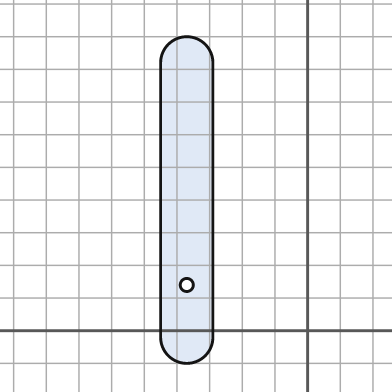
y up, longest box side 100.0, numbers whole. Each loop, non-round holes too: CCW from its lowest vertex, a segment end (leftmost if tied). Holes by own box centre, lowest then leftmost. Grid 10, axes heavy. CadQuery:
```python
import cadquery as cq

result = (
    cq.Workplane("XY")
    .moveTo(-45.0, -2.0)
    .threePointArc((-37.0, -10.0), (-29.0, -2.0))
    .lineTo(-29.0, 82.0)
    .threePointArc((-37.0, 90.0), (-45.0, 82.0))
    .close()
    .moveTo(-37.0, 14.0)
    .circle(2.0)
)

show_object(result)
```